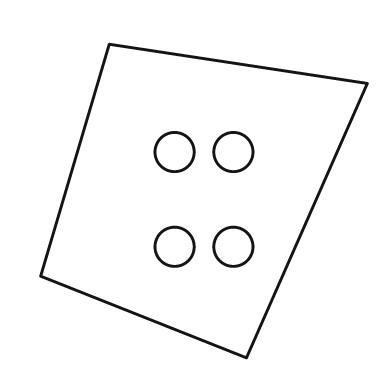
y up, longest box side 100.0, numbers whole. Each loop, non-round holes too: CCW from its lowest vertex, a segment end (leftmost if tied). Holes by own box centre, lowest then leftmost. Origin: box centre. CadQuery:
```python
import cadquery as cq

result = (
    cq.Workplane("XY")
    .moveTo(13.0, -48.0)
    .lineTo(50.0, 36.0)
    .lineTo(-29.0, 48.0)
    .lineTo(-50.0, -23.0)
    .close()
    .moveTo(-9.0, -14.0)
    .circle(6.0)
    .moveTo(9.0, -14.0)
    .circle(6.0)
    .moveTo(-9.0, 15.0)
    .circle(6.0)
    .moveTo(9.0, 15.0)
    .circle(6.0)
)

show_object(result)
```